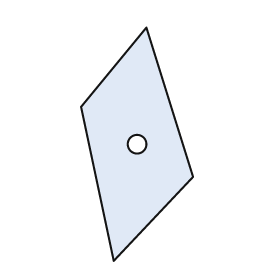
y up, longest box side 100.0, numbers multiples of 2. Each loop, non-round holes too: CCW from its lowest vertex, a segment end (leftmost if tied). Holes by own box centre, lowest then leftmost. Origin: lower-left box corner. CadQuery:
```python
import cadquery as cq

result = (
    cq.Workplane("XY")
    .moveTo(14.0, 0.0)
    .lineTo(48.0, 36.0)
    .lineTo(28.0, 100.0)
    .lineTo(0.0, 66.0)
    .close()
    .moveTo(24.0, 50.0)
    .circle(4.0)
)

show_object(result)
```